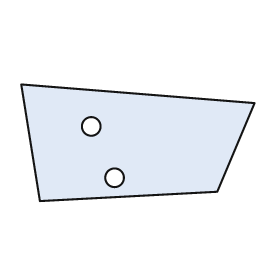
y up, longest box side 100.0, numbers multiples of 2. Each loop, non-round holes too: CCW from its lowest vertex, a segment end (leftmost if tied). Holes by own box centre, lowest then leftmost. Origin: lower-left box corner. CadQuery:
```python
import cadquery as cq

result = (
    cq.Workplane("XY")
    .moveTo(8.0, 0.0)
    .lineTo(84.0, 4.0)
    .lineTo(100.0, 42.0)
    .lineTo(0.0, 50.0)
    .close()
    .moveTo(40.0, 10.0)
    .circle(4.0)
    .moveTo(30.0, 32.0)
    .circle(4.0)
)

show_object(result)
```